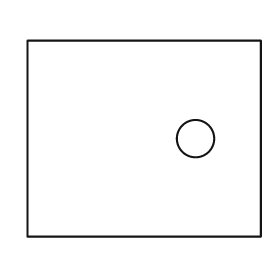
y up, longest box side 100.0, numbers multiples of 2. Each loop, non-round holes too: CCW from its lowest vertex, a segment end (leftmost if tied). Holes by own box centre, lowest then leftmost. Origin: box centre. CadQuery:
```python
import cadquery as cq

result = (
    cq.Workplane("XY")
    .moveTo(-50.0, -42.0)
    .lineTo(50.0, -42.0)
    .lineTo(50.0, 42.0)
    .lineTo(-50.0, 42.0)
    .close()
    .moveTo(22.0, 0.0)
    .circle(8.0)
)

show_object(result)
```